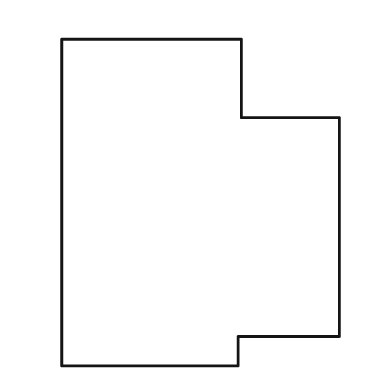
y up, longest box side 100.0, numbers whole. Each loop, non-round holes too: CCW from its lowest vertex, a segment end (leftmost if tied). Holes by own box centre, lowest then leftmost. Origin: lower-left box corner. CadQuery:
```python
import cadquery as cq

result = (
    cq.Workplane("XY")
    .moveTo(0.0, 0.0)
    .lineTo(54.0, 0.0)
    .lineTo(54.0, 9.0)
    .lineTo(85.0, 9.0)
    .lineTo(85.0, 76.0)
    .lineTo(55.0, 76.0)
    .lineTo(55.0, 100.0)
    .lineTo(0.0, 100.0)
    .close()
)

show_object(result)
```